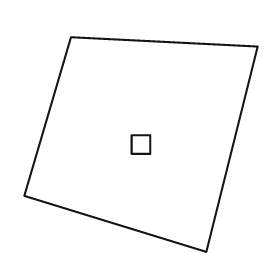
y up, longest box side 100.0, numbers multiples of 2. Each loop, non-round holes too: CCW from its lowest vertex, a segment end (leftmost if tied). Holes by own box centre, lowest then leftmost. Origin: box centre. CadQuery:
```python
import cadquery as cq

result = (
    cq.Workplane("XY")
    .moveTo(28.0, -46.0)
    .lineTo(50.0, 42.0)
    .lineTo(-30.0, 46.0)
    .lineTo(-50.0, -22.0)
    .close()
    .moveTo(-4.0, -4.0)
    .lineTo(4.0, -4.0)
    .lineTo(4.0, 4.0)
    .lineTo(-4.0, 4.0)
    .close()
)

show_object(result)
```